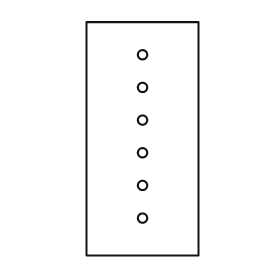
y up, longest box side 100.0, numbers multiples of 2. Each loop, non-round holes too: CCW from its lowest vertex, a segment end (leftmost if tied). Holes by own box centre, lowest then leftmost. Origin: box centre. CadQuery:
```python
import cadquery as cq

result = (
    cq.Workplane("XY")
    .moveTo(-24.0, -50.0)
    .lineTo(24.0, -50.0)
    .lineTo(24.0, 50.0)
    .lineTo(-24.0, 50.0)
    .close()
    .moveTo(0.0, -34.0)
    .circle(2.0)
    .moveTo(0.0, -20.0)
    .circle(2.0)
    .moveTo(0.0, -6.0)
    .circle(2.0)
    .moveTo(0.0, 8.0)
    .circle(2.0)
    .moveTo(0.0, 22.0)
    .circle(2.0)
    .moveTo(0.0, 36.0)
    .circle(2.0)
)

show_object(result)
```